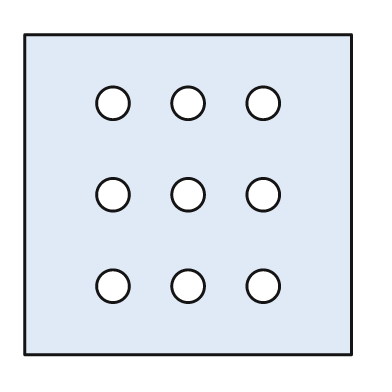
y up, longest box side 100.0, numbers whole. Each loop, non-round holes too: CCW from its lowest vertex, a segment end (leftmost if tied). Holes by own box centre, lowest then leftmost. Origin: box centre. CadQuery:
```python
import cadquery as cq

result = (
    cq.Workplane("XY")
    .moveTo(-50.0, -49.0)
    .lineTo(50.0, -49.0)
    .lineTo(50.0, 49.0)
    .lineTo(-50.0, 49.0)
    .close()
    .moveTo(-23.0, -28.0)
    .circle(5.0)
    .moveTo(0.0, -28.0)
    .circle(5.0)
    .moveTo(23.0, -28.0)
    .circle(5.0)
    .moveTo(-23.0, 0.0)
    .circle(5.0)
    .moveTo(0.0, 0.0)
    .circle(5.0)
    .moveTo(23.0, 0.0)
    .circle(5.0)
    .moveTo(-23.0, 28.0)
    .circle(5.0)
    .moveTo(0.0, 28.0)
    .circle(5.0)
    .moveTo(23.0, 28.0)
    .circle(5.0)
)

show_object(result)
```